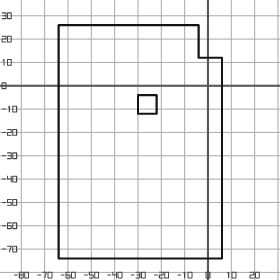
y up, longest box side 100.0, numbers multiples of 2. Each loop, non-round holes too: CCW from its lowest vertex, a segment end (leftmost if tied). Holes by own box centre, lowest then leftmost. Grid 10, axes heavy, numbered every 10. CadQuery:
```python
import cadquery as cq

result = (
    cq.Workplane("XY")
    .moveTo(-64.0, -74.0)
    .lineTo(6.0, -74.0)
    .lineTo(6.0, 12.0)
    .lineTo(-4.0, 12.0)
    .lineTo(-4.0, 26.0)
    .lineTo(-64.0, 26.0)
    .close()
    .moveTo(-30.0, -12.0)
    .lineTo(-22.0, -12.0)
    .lineTo(-22.0, -4.0)
    .lineTo(-30.0, -4.0)
    .close()
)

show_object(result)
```